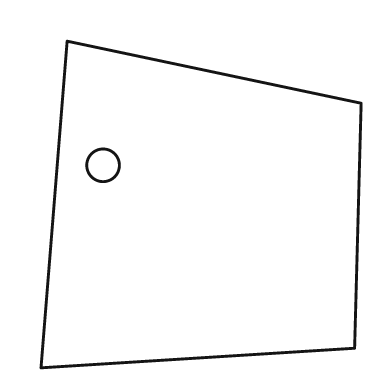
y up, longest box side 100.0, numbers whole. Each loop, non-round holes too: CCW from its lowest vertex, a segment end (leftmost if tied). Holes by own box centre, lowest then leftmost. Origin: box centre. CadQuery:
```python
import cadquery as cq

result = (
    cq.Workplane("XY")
    .moveTo(-49.0, -50.0)
    .lineTo(47.0, -44.0)
    .lineTo(49.0, 31.0)
    .lineTo(-41.0, 50.0)
    .close()
    .moveTo(-30.0, 12.0)
    .circle(5.0)
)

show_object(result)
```